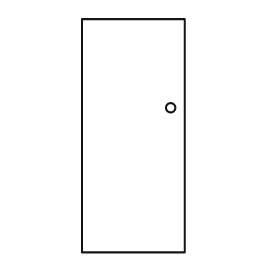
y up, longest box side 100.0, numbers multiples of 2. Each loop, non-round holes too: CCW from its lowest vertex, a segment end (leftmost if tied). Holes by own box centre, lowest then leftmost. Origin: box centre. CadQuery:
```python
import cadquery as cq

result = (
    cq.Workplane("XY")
    .moveTo(-22.0, -50.0)
    .lineTo(22.0, -50.0)
    .lineTo(22.0, 50.0)
    .lineTo(-22.0, 50.0)
    .close()
    .moveTo(16.0, 12.0)
    .circle(2.0)
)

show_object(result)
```